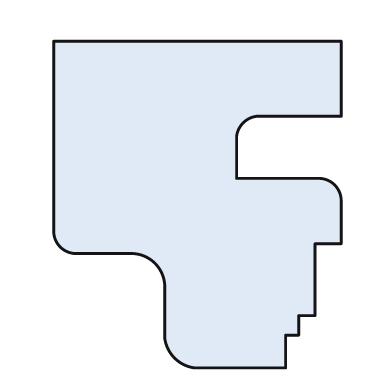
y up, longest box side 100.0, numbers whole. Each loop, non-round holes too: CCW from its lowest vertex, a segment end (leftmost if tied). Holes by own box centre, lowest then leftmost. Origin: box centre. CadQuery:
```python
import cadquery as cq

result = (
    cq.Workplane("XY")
    .moveTo(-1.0, -50.0)
    .lineTo(27.0, -50.0)
    .lineTo(27.0, -40.0)
    .lineTo(31.0, -40.0)
    .lineTo(31.0, -34.0)
    .lineTo(36.0, -34.0)
    .lineTo(36.0, -12.0)
    .lineTo(44.0, -12.0)
    .lineTo(44.0, 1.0)
    .threePointArc((42.0, 6.0), (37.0, 8.0))
    .lineTo(12.0, 8.0)
    .lineTo(12.0, 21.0)
    .threePointArc((14.0, 25.0), (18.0, 27.0))
    .lineTo(44.0, 27.0)
    .lineTo(44.0, 50.0)
    .lineTo(-44.0, 50.0)
    .lineTo(-44.0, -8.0)
    .threePointArc((-42.0, -13.0), (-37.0, -15.0))
    .lineTo(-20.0, -15.0)
    .threePointArc((-13.0, -18.0), (-10.0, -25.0))
    .lineTo(-10.0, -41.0)
    .threePointArc((-7.0, -47.0), (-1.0, -50.0))
    .close()
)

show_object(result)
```